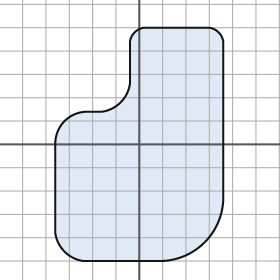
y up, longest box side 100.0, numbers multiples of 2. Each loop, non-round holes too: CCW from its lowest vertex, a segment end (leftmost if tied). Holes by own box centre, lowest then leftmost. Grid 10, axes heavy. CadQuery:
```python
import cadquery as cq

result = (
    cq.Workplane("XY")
    .moveTo(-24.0, -50.0)
    .lineTo(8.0, -50.0)
    .threePointArc((28.0, -42.0), (36.0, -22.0))
    .lineTo(36.0, 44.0)
    .threePointArc((34.0, 48.0), (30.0, 50.0))
    .lineTo(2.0, 50.0)
    .threePointArc((-2.0, 48.0), (-4.0, 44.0))
    .lineTo(-4.0, 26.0)
    .threePointArc((-8.0, 18.0), (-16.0, 14.0))
    .lineTo(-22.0, 14.0)
    .threePointArc((-32.0, 10.0), (-36.0, 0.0))
    .lineTo(-36.0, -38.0)
    .threePointArc((-32.0, -46.0), (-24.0, -50.0))
    .close()
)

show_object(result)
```